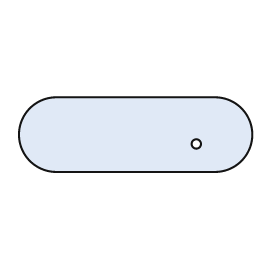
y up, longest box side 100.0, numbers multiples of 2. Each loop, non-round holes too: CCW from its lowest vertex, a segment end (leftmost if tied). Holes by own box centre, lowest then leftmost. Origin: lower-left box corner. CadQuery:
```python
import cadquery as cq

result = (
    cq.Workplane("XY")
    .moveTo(16.0, 0.0)
    .lineTo(84.0, 0.0)
    .threePointArc((100.0, 16.0), (84.0, 32.0))
    .lineTo(16.0, 32.0)
    .threePointArc((0.0, 16.0), (16.0, 0.0))
    .close()
    .moveTo(76.0, 12.0)
    .circle(2.0)
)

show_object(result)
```